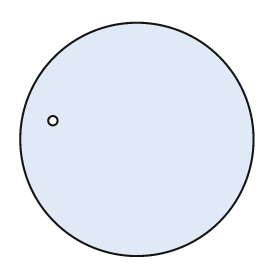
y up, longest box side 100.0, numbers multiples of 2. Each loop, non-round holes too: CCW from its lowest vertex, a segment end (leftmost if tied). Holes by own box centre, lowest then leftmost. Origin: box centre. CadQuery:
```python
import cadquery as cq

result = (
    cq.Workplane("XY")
    .moveTo(0.0, 0.0)
    .circle(50.0)
    .moveTo(-36.0, 8.0)
    .circle(2.0)
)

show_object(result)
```